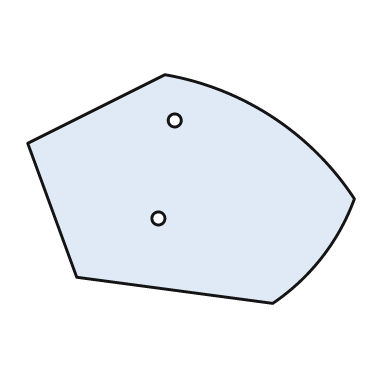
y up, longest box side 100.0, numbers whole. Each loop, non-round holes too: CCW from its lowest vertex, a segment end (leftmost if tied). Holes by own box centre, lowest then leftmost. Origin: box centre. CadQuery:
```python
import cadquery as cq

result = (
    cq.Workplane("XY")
    .moveTo(25.0, -35.0)
    .threePointArc((40.0, -21.0), (50.0, -3.0))
    .threePointArc((25.0, 22.0), (-8.0, 35.0))
    .lineTo(-50.0, 14.0)
    .lineTo(-35.0, -27.0)
    .close()
    .moveTo(-10.0, -9.0)
    .circle(2.0)
    .moveTo(-5.0, 21.0)
    .circle(2.0)
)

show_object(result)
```